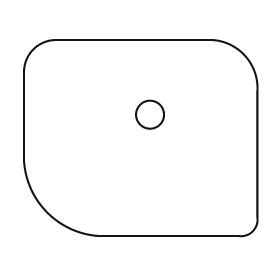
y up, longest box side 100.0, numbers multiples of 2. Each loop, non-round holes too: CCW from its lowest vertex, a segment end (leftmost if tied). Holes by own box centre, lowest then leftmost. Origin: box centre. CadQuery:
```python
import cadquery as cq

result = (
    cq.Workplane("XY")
    .moveTo(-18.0, -42.0)
    .lineTo(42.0, -42.0)
    .threePointArc((48.0, -40.0), (50.0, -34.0))
    .lineTo(50.0, 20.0)
    .threePointArc((44.0, 36.0), (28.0, 42.0))
    .lineTo(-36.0, 42.0)
    .threePointArc((-46.0, 38.0), (-50.0, 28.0))
    .lineTo(-50.0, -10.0)
    .threePointArc((-40.0, -32.0), (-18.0, -42.0))
    .close()
    .moveTo(4.0, 10.0)
    .circle(6.0)
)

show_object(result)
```